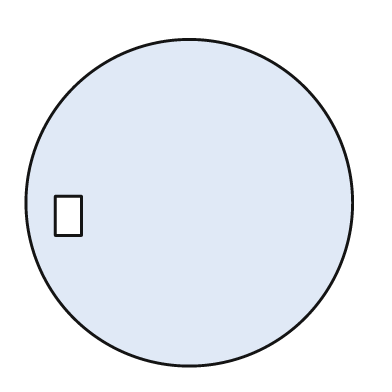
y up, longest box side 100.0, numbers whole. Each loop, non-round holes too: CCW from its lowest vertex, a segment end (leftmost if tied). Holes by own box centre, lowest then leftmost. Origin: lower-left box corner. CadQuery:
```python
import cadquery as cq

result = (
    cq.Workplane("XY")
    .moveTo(50.0, 50.0)
    .circle(50.0)
    .moveTo(9.0, 40.0)
    .lineTo(17.0, 40.0)
    .lineTo(17.0, 52.0)
    .lineTo(9.0, 52.0)
    .close()
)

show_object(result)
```